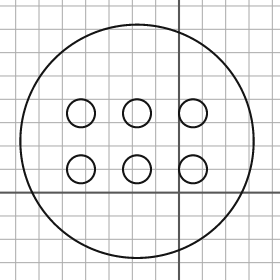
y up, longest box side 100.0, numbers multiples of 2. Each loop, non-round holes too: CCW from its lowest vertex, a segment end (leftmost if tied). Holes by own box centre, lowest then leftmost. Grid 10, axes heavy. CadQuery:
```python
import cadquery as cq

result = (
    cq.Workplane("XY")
    .moveTo(-18.0, 22.0)
    .circle(50.0)
    .moveTo(-42.0, 10.0)
    .circle(6.0)
    .moveTo(-18.0, 10.0)
    .circle(6.0)
    .moveTo(6.0, 10.0)
    .circle(6.0)
    .moveTo(-42.0, 34.0)
    .circle(6.0)
    .moveTo(-18.0, 34.0)
    .circle(6.0)
    .moveTo(6.0, 34.0)
    .circle(6.0)
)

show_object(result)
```